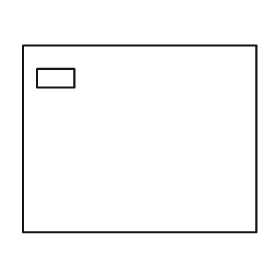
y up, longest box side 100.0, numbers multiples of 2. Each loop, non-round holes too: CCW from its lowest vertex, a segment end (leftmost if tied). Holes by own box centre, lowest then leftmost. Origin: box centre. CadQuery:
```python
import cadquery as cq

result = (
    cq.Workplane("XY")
    .moveTo(-50.0, -40.0)
    .lineTo(50.0, -40.0)
    .lineTo(50.0, 40.0)
    .lineTo(-50.0, 40.0)
    .close()
    .moveTo(-44.0, 22.0)
    .lineTo(-28.0, 22.0)
    .lineTo(-28.0, 30.0)
    .lineTo(-44.0, 30.0)
    .close()
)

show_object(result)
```